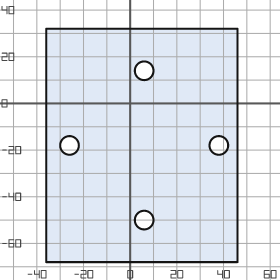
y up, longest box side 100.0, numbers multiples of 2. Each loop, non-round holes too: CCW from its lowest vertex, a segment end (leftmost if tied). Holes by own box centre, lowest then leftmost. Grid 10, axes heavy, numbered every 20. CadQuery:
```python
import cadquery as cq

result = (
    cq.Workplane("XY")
    .moveTo(-36.0, -68.0)
    .lineTo(46.0, -68.0)
    .lineTo(46.0, 32.0)
    .lineTo(-36.0, 32.0)
    .close()
    .moveTo(6.0, -50.0)
    .circle(4.0)
    .moveTo(-26.0, -18.0)
    .circle(4.0)
    .moveTo(38.0, -18.0)
    .circle(4.0)
    .moveTo(6.0, 14.0)
    .circle(4.0)
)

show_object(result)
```